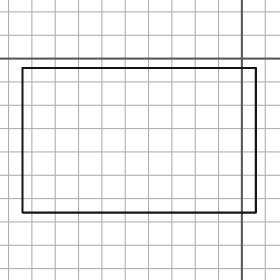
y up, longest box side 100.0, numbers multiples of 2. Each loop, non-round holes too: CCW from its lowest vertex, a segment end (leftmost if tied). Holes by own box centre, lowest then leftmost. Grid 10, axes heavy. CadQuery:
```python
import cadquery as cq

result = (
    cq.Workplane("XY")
    .moveTo(-94.0, -66.0)
    .lineTo(6.0, -66.0)
    .lineTo(6.0, -4.0)
    .lineTo(-94.0, -4.0)
    .close()
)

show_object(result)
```